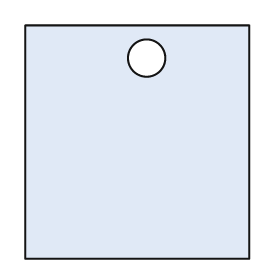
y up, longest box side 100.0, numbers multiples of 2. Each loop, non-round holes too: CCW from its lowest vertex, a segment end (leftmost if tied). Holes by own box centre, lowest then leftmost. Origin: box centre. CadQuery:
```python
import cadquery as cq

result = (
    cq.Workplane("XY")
    .moveTo(-48.0, -50.0)
    .lineTo(48.0, -50.0)
    .lineTo(48.0, 50.0)
    .lineTo(-48.0, 50.0)
    .close()
    .moveTo(4.0, 36.0)
    .circle(8.0)
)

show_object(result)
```